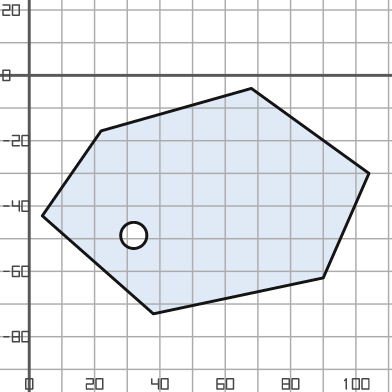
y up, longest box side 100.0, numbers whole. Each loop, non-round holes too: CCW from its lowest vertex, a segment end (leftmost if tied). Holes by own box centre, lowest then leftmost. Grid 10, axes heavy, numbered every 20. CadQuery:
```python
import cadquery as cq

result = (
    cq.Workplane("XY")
    .moveTo(38.0, -73.0)
    .lineTo(90.0, -62.0)
    .lineTo(104.0, -30.0)
    .lineTo(68.0, -4.0)
    .lineTo(22.0, -17.0)
    .lineTo(4.0, -43.0)
    .close()
    .moveTo(32.0, -49.0)
    .circle(4.0)
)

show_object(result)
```